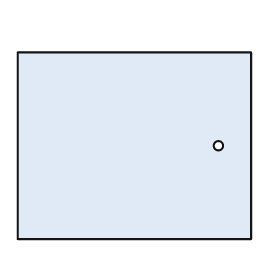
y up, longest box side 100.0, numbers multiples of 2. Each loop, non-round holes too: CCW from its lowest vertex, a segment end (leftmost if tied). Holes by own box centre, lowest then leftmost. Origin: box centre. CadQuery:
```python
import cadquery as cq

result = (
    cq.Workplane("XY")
    .moveTo(-50.0, -40.0)
    .lineTo(50.0, -40.0)
    .lineTo(50.0, 40.0)
    .lineTo(-50.0, 40.0)
    .close()
    .moveTo(36.0, 0.0)
    .circle(2.0)
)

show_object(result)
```